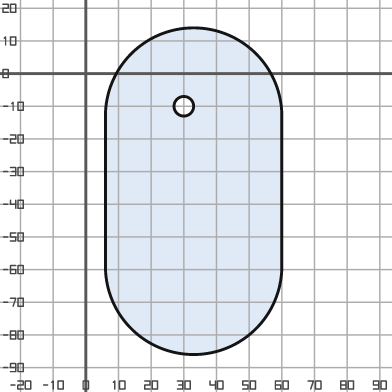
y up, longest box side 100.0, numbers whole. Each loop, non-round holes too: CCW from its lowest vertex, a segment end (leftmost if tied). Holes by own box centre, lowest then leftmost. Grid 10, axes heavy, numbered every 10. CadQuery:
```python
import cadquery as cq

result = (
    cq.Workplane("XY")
    .moveTo(6.0, -59.0)
    .threePointArc((33.0, -86.0), (60.0, -59.0))
    .lineTo(60.0, -13.0)
    .threePointArc((33.0, 14.0), (6.0, -13.0))
    .close()
    .moveTo(30.0, -10.0)
    .circle(3.0)
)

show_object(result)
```